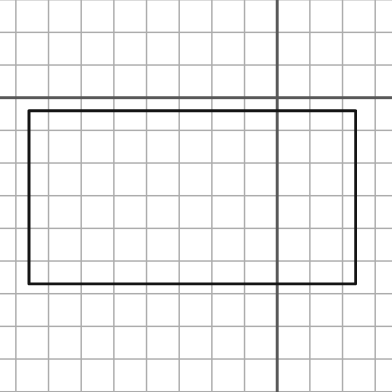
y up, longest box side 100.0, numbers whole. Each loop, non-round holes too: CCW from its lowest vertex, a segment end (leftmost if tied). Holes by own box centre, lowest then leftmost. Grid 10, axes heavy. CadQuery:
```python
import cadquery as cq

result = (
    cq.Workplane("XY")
    .moveTo(-76.0, -57.0)
    .lineTo(24.0, -57.0)
    .lineTo(24.0, -4.0)
    .lineTo(-76.0, -4.0)
    .close()
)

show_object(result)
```